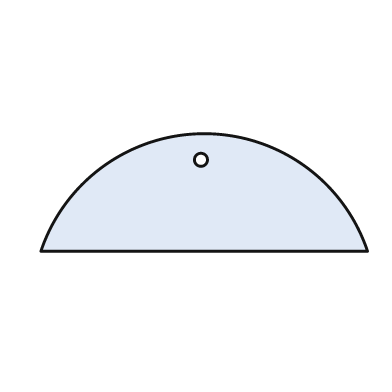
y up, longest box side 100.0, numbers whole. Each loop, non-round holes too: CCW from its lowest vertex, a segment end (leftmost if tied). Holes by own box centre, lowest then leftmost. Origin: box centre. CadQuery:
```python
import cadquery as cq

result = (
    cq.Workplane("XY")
    .moveTo(-50.0, -18.0)
    .lineTo(50.0, -18.0)
    .threePointArc((0.0, 18.0), (-50.0, -18.0))
    .close()
    .moveTo(-1.0, 10.0)
    .circle(2.0)
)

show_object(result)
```